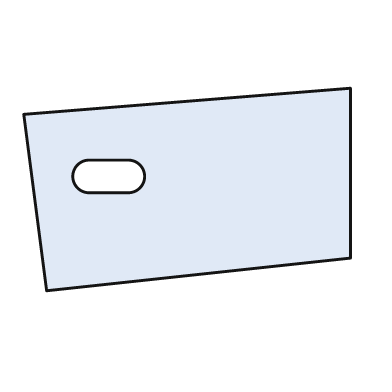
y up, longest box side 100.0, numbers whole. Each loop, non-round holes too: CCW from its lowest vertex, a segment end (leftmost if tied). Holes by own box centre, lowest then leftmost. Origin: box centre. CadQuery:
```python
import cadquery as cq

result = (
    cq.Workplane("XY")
    .moveTo(-43.0, -31.0)
    .lineTo(50.0, -21.0)
    .lineTo(50.0, 31.0)
    .lineTo(-50.0, 23.0)
    .close()
    .moveTo(-30.0, -1.0)
    .lineTo(-18.0, -1.0)
    .threePointArc((-13.0, 4.0), (-18.0, 9.0))
    .lineTo(-30.0, 9.0)
    .threePointArc((-35.0, 4.0), (-30.0, -1.0))
    .close()
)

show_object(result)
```